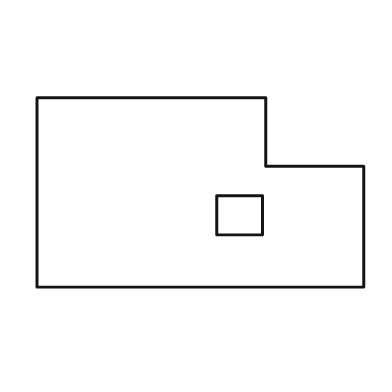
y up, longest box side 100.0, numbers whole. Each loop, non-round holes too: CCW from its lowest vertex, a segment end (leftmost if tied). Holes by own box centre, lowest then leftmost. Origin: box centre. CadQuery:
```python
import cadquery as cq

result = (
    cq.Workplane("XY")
    .moveTo(-50.0, -29.0)
    .lineTo(50.0, -29.0)
    .lineTo(50.0, 8.0)
    .lineTo(20.0, 8.0)
    .lineTo(20.0, 29.0)
    .lineTo(-50.0, 29.0)
    .close()
    .moveTo(5.0, -13.0)
    .lineTo(19.0, -13.0)
    .lineTo(19.0, -1.0)
    .lineTo(5.0, -1.0)
    .close()
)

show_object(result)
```